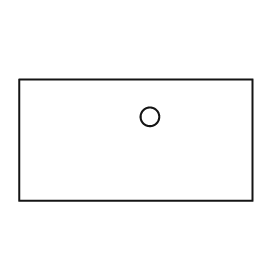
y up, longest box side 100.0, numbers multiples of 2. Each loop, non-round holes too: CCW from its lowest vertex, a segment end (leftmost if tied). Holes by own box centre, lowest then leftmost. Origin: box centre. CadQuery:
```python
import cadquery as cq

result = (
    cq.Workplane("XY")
    .moveTo(-50.0, -26.0)
    .lineTo(50.0, -26.0)
    .lineTo(50.0, 26.0)
    .lineTo(-50.0, 26.0)
    .close()
    .moveTo(6.0, 10.0)
    .circle(4.0)
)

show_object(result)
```